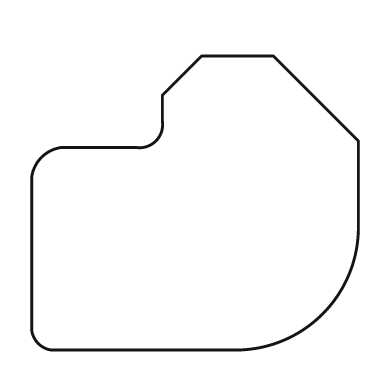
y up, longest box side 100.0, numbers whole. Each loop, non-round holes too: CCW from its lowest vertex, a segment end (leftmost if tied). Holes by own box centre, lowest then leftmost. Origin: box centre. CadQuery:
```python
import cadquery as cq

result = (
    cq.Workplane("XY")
    .moveTo(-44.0, -45.0)
    .lineTo(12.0, -45.0)
    .threePointArc((39.0, -34.0), (50.0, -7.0))
    .lineTo(50.0, 19.0)
    .lineTo(24.0, 45.0)
    .lineTo(2.0, 45.0)
    .lineTo(-10.0, 33.0)
    .lineTo(-10.0, 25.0)
    .threePointArc((-12.0, 19.0), (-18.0, 17.0))
    .lineTo(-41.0, 17.0)
    .threePointArc((-47.0, 14.0), (-50.0, 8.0))
    .lineTo(-50.0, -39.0)
    .threePointArc((-48.0, -43.0), (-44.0, -45.0))
    .close()
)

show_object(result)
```